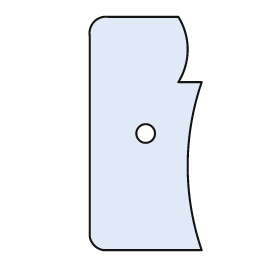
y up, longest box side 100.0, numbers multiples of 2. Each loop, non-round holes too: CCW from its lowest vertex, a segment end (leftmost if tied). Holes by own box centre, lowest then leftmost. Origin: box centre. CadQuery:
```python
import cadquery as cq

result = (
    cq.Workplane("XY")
    .moveTo(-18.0, -50.0)
    .lineTo(24.0, -50.0)
    .threePointArc((18.0, -14.0), (24.0, 22.0))
    .lineTo(14.0, 22.0)
    .threePointArc((18.0, 36.0), (14.0, 50.0))
    .lineTo(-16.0, 50.0)
    .threePointArc((-22.0, 48.0), (-24.0, 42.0))
    .lineTo(-24.0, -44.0)
    .threePointArc((-22.0, -48.0), (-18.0, -50.0))
    .close()
    .moveTo(0.0, 0.0)
    .circle(4.0)
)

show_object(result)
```